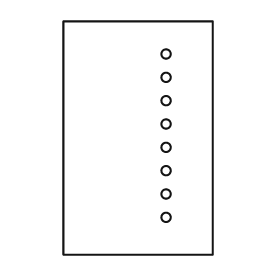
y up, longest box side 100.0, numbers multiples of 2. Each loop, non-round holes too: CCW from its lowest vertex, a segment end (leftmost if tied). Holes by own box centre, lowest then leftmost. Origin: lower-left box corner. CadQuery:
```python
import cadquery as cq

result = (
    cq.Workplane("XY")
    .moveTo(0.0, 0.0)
    .lineTo(64.0, 0.0)
    .lineTo(64.0, 100.0)
    .lineTo(0.0, 100.0)
    .close()
    .moveTo(44.0, 16.0)
    .circle(2.0)
    .moveTo(44.0, 26.0)
    .circle(2.0)
    .moveTo(44.0, 36.0)
    .circle(2.0)
    .moveTo(44.0, 46.0)
    .circle(2.0)
    .moveTo(44.0, 56.0)
    .circle(2.0)
    .moveTo(44.0, 66.0)
    .circle(2.0)
    .moveTo(44.0, 76.0)
    .circle(2.0)
    .moveTo(44.0, 86.0)
    .circle(2.0)
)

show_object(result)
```